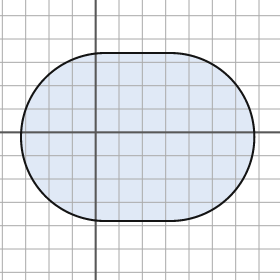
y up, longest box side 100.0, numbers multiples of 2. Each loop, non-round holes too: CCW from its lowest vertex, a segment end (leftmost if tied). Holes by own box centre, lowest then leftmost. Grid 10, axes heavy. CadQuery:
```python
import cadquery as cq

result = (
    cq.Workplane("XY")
    .moveTo(4.0, -38.0)
    .lineTo(32.0, -38.0)
    .threePointArc((68.0, -2.0), (32.0, 34.0))
    .lineTo(4.0, 34.0)
    .threePointArc((-32.0, -2.0), (4.0, -38.0))
    .close()
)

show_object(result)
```